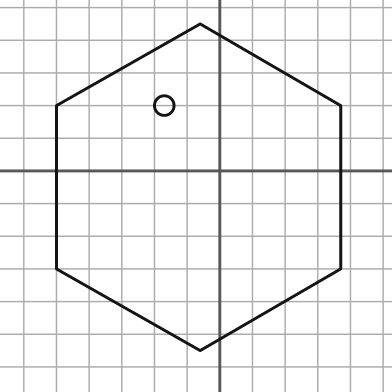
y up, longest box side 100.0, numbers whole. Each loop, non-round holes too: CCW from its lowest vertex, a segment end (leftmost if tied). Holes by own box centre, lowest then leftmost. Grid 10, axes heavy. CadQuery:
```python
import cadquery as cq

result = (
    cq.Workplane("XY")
    .moveTo(-6.0, -55.0)
    .lineTo(37.0, -30.0)
    .lineTo(37.0, 20.0)
    .lineTo(-6.0, 45.0)
    .lineTo(-50.0, 20.0)
    .lineTo(-50.0, -30.0)
    .close()
    .moveTo(-17.0, 20.0)
    .circle(3.0)
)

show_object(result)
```